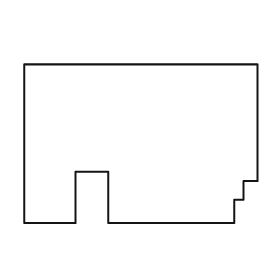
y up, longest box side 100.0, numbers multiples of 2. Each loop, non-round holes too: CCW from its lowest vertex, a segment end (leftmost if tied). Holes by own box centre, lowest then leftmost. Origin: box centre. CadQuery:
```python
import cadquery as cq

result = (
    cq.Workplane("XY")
    .moveTo(-50.0, -34.0)
    .lineTo(-28.0, -34.0)
    .lineTo(-28.0, -12.0)
    .lineTo(-14.0, -12.0)
    .lineTo(-14.0, -34.0)
    .lineTo(40.0, -34.0)
    .lineTo(40.0, -24.0)
    .lineTo(44.0, -24.0)
    .lineTo(44.0, -16.0)
    .lineTo(50.0, -16.0)
    .lineTo(50.0, 34.0)
    .lineTo(-50.0, 34.0)
    .close()
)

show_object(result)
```